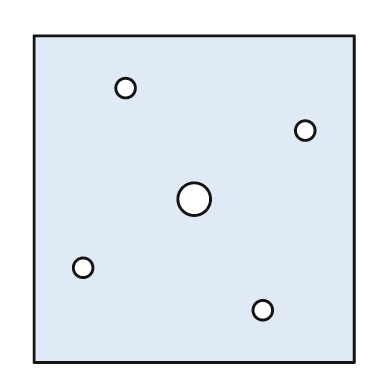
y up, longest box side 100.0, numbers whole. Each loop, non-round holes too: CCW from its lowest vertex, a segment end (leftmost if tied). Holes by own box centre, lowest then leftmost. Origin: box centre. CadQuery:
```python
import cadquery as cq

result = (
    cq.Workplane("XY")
    .moveTo(-49.0, -50.0)
    .lineTo(49.0, -50.0)
    .lineTo(49.0, 50.0)
    .lineTo(-49.0, 50.0)
    .close()
    .moveTo(21.0, -34.0)
    .circle(3.0)
    .moveTo(-34.0, -21.0)
    .circle(3.0)
    .moveTo(0.0, 0.0)
    .circle(5.0)
    .moveTo(34.0, 21.0)
    .circle(3.0)
    .moveTo(-21.0, 34.0)
    .circle(3.0)
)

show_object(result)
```